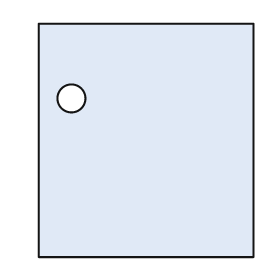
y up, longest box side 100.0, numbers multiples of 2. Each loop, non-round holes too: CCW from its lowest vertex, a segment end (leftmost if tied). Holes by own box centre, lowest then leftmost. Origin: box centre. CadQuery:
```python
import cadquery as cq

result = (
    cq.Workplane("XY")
    .moveTo(-46.0, -50.0)
    .lineTo(46.0, -50.0)
    .lineTo(46.0, 50.0)
    .lineTo(-46.0, 50.0)
    .close()
    .moveTo(-32.0, 18.0)
    .circle(6.0)
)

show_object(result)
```